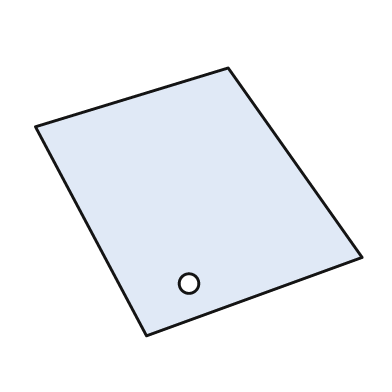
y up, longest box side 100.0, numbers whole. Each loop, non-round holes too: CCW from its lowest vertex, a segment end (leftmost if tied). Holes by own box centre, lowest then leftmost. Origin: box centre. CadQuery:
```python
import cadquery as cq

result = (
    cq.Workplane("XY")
    .moveTo(-16.0, -41.0)
    .lineTo(50.0, -17.0)
    .lineTo(9.0, 41.0)
    .lineTo(-50.0, 23.0)
    .close()
    .moveTo(-3.0, -25.0)
    .circle(3.0)
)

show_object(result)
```